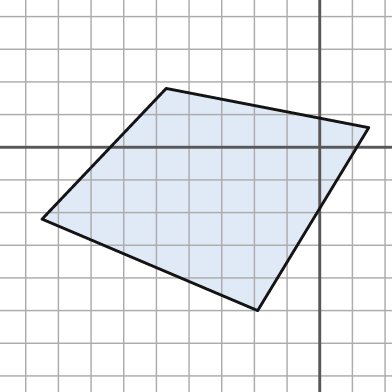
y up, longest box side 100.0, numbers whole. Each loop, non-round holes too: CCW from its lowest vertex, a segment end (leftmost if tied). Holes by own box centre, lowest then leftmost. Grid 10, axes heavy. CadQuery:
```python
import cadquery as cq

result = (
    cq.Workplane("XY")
    .moveTo(-19.0, -50.0)
    .lineTo(15.0, 6.0)
    .lineTo(-47.0, 18.0)
    .lineTo(-85.0, -22.0)
    .close()
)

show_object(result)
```